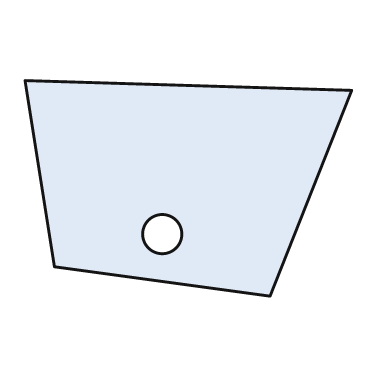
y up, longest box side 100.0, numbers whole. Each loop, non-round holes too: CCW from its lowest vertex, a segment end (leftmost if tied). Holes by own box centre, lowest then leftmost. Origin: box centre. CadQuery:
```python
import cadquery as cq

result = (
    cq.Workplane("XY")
    .moveTo(25.0, -33.0)
    .lineTo(50.0, 30.0)
    .lineTo(-50.0, 33.0)
    .lineTo(-41.0, -24.0)
    .close()
    .moveTo(-8.0, -14.0)
    .circle(6.0)
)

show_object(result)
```